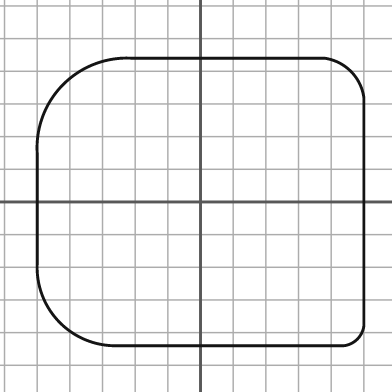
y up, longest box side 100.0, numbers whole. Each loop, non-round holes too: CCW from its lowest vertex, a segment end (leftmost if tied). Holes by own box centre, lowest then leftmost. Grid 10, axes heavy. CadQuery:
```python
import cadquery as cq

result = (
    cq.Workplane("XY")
    .moveTo(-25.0, -44.0)
    .lineTo(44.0, -44.0)
    .threePointArc((48.0, -42.0), (50.0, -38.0))
    .lineTo(50.0, 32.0)
    .threePointArc((46.0, 40.0), (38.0, 44.0))
    .lineTo(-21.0, 44.0)
    .threePointArc((-42.0, 36.0), (-50.0, 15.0))
    .lineTo(-50.0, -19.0)
    .threePointArc((-43.0, -37.0), (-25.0, -44.0))
    .close()
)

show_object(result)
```